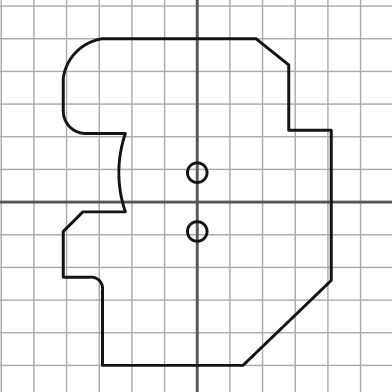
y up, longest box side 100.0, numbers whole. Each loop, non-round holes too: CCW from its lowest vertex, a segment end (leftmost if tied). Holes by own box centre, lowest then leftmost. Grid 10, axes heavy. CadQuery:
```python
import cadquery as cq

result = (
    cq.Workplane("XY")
    .moveTo(-29.0, -50.0)
    .lineTo(14.0, -50.0)
    .lineTo(41.0, -24.0)
    .lineTo(41.0, 22.0)
    .lineTo(28.0, 22.0)
    .lineTo(28.0, 42.0)
    .lineTo(18.0, 50.0)
    .lineTo(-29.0, 50.0)
    .threePointArc((-37.0, 46.0), (-41.0, 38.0))
    .lineTo(-41.0, 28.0)
    .threePointArc((-39.0, 23.0), (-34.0, 21.0))
    .lineTo(-22.0, 21.0)
    .threePointArc((-24.0, 9.0), (-22.0, -3.0))
    .lineTo(-35.0, -3.0)
    .lineTo(-41.0, -9.0)
    .lineTo(-41.0, -23.0)
    .lineTo(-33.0, -23.0)
    .threePointArc((-30.0, -24.0), (-29.0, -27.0))
    .close()
    .moveTo(0.0, -9.0)
    .circle(3.0)
    .moveTo(0.0, 9.0)
    .circle(3.0)
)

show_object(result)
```